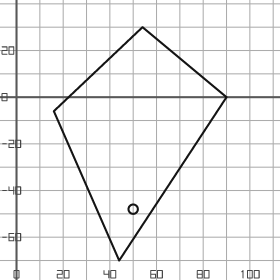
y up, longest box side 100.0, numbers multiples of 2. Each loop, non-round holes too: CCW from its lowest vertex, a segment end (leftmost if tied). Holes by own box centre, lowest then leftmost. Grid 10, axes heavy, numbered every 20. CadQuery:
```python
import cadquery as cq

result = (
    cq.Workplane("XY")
    .moveTo(44.0, -70.0)
    .lineTo(90.0, 0.0)
    .lineTo(54.0, 30.0)
    .lineTo(16.0, -6.0)
    .close()
    .moveTo(50.0, -48.0)
    .circle(2.0)
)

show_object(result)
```